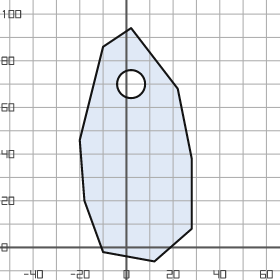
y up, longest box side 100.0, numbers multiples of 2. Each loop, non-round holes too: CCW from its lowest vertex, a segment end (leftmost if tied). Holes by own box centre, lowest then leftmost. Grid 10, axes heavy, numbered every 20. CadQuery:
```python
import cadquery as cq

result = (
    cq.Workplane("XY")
    .moveTo(12.0, -6.0)
    .lineTo(28.0, 8.0)
    .lineTo(28.0, 38.0)
    .lineTo(22.0, 68.0)
    .lineTo(2.0, 94.0)
    .lineTo(-10.0, 86.0)
    .lineTo(-20.0, 46.0)
    .lineTo(-18.0, 20.0)
    .lineTo(-10.0, -2.0)
    .close()
    .moveTo(2.0, 70.0)
    .circle(6.0)
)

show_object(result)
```